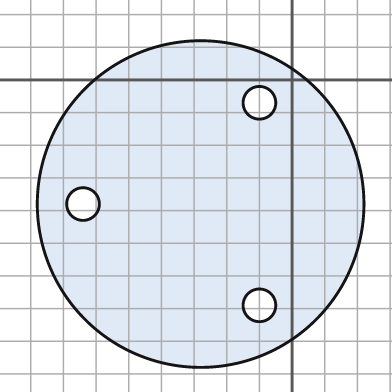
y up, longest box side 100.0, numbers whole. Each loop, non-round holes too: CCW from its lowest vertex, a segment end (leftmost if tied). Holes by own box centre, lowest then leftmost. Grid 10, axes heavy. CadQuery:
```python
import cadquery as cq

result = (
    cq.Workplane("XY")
    .moveTo(-28.0, -38.0)
    .circle(50.0)
    .moveTo(-10.0, -69.0)
    .circle(5.0)
    .moveTo(-64.0, -38.0)
    .circle(5.0)
    .moveTo(-10.0, -7.0)
    .circle(5.0)
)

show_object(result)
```